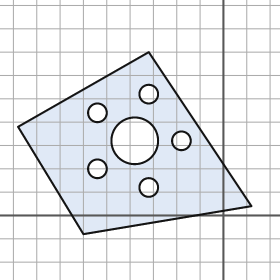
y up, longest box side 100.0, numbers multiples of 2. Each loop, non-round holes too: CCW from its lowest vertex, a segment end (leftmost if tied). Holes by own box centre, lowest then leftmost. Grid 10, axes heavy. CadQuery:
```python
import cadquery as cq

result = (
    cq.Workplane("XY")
    .moveTo(-60.0, -8.0)
    .lineTo(12.0, 4.0)
    .lineTo(-32.0, 70.0)
    .lineTo(-88.0, 38.0)
    .close()
    .moveTo(-32.0, 12.0)
    .circle(4.0)
    .moveTo(-54.0, 20.0)
    .circle(4.0)
    .moveTo(-38.0, 32.0)
    .circle(10.0)
    .moveTo(-18.0, 32.0)
    .circle(4.0)
    .moveTo(-54.0, 44.0)
    .circle(4.0)
    .moveTo(-32.0, 52.0)
    .circle(4.0)
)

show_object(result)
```